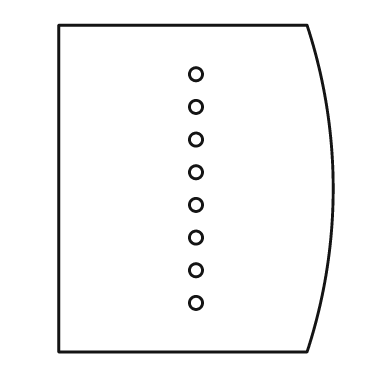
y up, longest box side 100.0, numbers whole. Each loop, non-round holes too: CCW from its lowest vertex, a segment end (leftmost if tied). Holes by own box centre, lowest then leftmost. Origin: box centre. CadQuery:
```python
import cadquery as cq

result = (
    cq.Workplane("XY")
    .moveTo(-42.0, -50.0)
    .lineTo(34.0, -50.0)
    .threePointArc((42.0, 0.0), (34.0, 50.0))
    .lineTo(-42.0, 50.0)
    .close()
    .moveTo(0.0, -35.0)
    .circle(2.0)
    .moveTo(0.0, -25.0)
    .circle(2.0)
    .moveTo(0.0, -15.0)
    .circle(2.0)
    .moveTo(0.0, -5.0)
    .circle(2.0)
    .moveTo(0.0, 5.0)
    .circle(2.0)
    .moveTo(0.0, 15.0)
    .circle(2.0)
    .moveTo(0.0, 25.0)
    .circle(2.0)
    .moveTo(0.0, 35.0)
    .circle(2.0)
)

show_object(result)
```